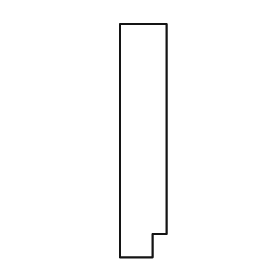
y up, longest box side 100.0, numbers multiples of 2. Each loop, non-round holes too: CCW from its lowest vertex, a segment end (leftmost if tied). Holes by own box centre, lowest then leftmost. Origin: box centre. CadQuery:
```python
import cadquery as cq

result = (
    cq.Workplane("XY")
    .moveTo(-10.0, -50.0)
    .lineTo(4.0, -50.0)
    .lineTo(4.0, -40.0)
    .lineTo(10.0, -40.0)
    .lineTo(10.0, 50.0)
    .lineTo(-10.0, 50.0)
    .close()
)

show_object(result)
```